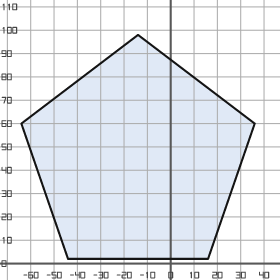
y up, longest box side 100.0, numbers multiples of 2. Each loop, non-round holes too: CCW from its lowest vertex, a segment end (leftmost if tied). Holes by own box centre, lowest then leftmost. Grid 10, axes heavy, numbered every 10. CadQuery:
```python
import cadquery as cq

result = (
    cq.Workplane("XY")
    .moveTo(-44.0, 2.0)
    .lineTo(16.0, 2.0)
    .lineTo(36.0, 60.0)
    .lineTo(-14.0, 98.0)
    .lineTo(-64.0, 60.0)
    .close()
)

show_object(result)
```